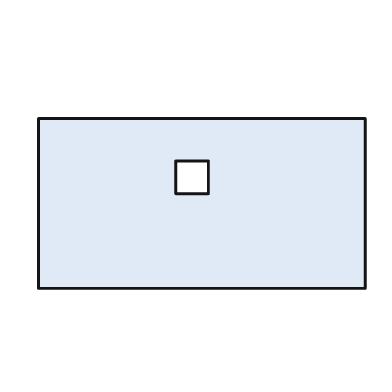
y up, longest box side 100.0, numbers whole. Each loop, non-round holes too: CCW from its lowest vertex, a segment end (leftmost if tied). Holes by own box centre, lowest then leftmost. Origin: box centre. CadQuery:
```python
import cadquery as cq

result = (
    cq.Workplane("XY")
    .moveTo(-50.0, -26.0)
    .lineTo(50.0, -26.0)
    .lineTo(50.0, 26.0)
    .lineTo(-50.0, 26.0)
    .close()
    .moveTo(-8.0, 3.0)
    .lineTo(2.0, 3.0)
    .lineTo(2.0, 13.0)
    .lineTo(-8.0, 13.0)
    .close()
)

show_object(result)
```